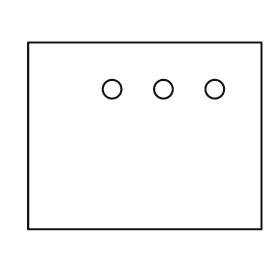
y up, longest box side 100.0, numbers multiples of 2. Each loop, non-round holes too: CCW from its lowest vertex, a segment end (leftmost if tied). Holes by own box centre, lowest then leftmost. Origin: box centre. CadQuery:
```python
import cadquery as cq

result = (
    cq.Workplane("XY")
    .moveTo(-50.0, -40.0)
    .lineTo(50.0, -40.0)
    .lineTo(50.0, 40.0)
    .lineTo(-50.0, 40.0)
    .close()
    .moveTo(-14.0, 20.0)
    .circle(4.0)
    .moveTo(8.0, 20.0)
    .circle(4.0)
    .moveTo(30.0, 20.0)
    .circle(4.0)
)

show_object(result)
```